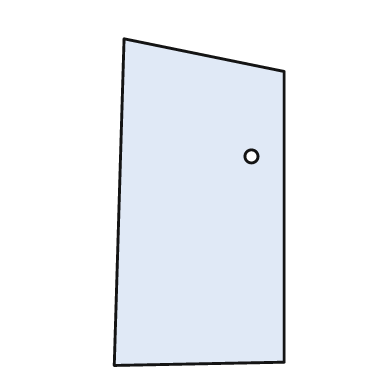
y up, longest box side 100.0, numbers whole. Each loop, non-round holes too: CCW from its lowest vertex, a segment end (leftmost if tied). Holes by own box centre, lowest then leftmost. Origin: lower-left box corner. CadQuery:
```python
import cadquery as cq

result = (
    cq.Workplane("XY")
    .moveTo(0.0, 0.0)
    .lineTo(52.0, 1.0)
    .lineTo(52.0, 90.0)
    .lineTo(3.0, 100.0)
    .close()
    .moveTo(42.0, 64.0)
    .circle(2.0)
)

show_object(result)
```